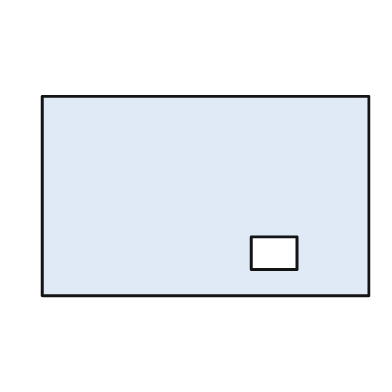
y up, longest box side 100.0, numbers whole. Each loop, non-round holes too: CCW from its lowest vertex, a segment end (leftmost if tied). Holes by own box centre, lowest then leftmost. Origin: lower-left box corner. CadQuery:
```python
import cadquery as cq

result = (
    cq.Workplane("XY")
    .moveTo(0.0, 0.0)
    .lineTo(100.0, 0.0)
    .lineTo(100.0, 61.0)
    .lineTo(0.0, 61.0)
    .close()
    .moveTo(64.0, 8.0)
    .lineTo(78.0, 8.0)
    .lineTo(78.0, 18.0)
    .lineTo(64.0, 18.0)
    .close()
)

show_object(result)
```